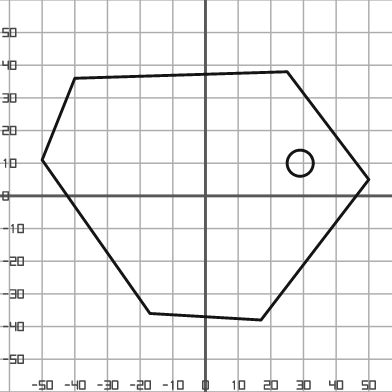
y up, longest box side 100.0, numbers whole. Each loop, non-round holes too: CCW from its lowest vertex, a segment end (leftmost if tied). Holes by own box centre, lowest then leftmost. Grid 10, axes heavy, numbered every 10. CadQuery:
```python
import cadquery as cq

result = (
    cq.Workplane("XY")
    .moveTo(17.0, -38.0)
    .lineTo(50.0, 5.0)
    .lineTo(25.0, 38.0)
    .lineTo(-40.0, 36.0)
    .lineTo(-50.0, 11.0)
    .lineTo(-17.0, -36.0)
    .close()
    .moveTo(29.0, 10.0)
    .circle(4.0)
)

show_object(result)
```